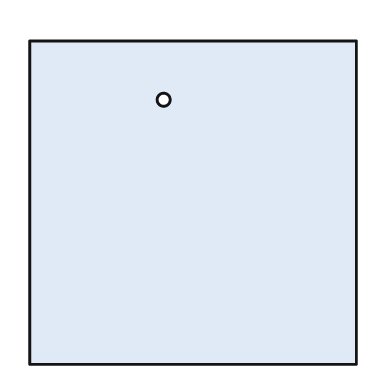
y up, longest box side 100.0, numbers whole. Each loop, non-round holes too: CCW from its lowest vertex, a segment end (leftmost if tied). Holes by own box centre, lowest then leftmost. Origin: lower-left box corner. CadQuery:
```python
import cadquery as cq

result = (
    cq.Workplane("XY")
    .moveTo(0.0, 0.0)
    .lineTo(100.0, 0.0)
    .lineTo(100.0, 99.0)
    .lineTo(0.0, 99.0)
    .close()
    .moveTo(41.0, 81.0)
    .circle(2.0)
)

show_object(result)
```